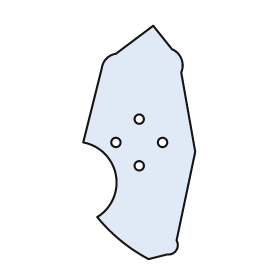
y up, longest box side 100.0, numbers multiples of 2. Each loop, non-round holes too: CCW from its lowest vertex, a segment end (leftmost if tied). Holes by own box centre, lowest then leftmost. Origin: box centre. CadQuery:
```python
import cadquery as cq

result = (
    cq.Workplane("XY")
    .moveTo(4.0, -50.0)
    .lineTo(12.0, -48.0)
    .threePointArc((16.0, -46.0), (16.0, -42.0))
    .lineTo(24.0, -4.0)
    .lineTo(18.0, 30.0)
    .threePointArc((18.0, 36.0), (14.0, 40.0))
    .lineTo(6.0, 50.0)
    .lineTo(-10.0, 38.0)
    .threePointArc((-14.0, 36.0), (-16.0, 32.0))
    .lineTo(-24.0, 0.0)
    .threePointArc((-10.0, -14.0), (-18.0, -32.0))
    .threePointArc((-8.0, -42.0), (4.0, -50.0))
    .close()
    .moveTo(0.0, -10.0)
    .circle(2.0)
    .moveTo(-10.0, 0.0)
    .circle(2.0)
    .moveTo(10.0, 0.0)
    .circle(2.0)
    .moveTo(0.0, 10.0)
    .circle(2.0)
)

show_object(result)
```